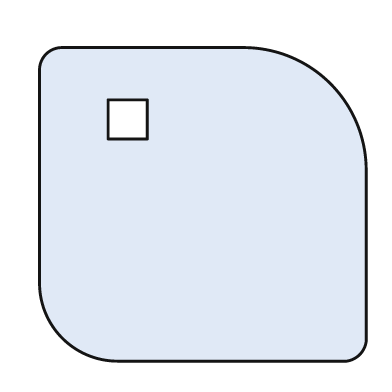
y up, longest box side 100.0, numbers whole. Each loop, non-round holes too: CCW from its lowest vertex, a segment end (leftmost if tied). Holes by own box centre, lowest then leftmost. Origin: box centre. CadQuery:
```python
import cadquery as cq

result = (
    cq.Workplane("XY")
    .moveTo(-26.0, -48.0)
    .lineTo(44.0, -48.0)
    .threePointArc((48.0, -46.0), (50.0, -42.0))
    .lineTo(50.0, 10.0)
    .threePointArc((39.0, 37.0), (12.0, 48.0))
    .lineTo(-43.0, 48.0)
    .threePointArc((-48.0, 46.0), (-50.0, 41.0))
    .lineTo(-50.0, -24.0)
    .threePointArc((-43.0, -41.0), (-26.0, -48.0))
    .close()
    .moveTo(-29.0, 20.0)
    .lineTo(-17.0, 20.0)
    .lineTo(-17.0, 32.0)
    .lineTo(-29.0, 32.0)
    .close()
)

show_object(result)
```